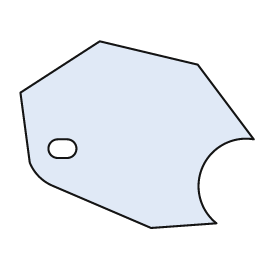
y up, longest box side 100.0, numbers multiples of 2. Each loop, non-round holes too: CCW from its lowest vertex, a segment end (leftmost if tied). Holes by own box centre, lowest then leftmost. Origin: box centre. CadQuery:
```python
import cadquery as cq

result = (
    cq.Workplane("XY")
    .moveTo(6.0, -40.0)
    .lineTo(34.0, -38.0)
    .threePointArc((28.0, -14.0), (50.0, -2.0))
    .lineTo(26.0, 30.0)
    .lineTo(-16.0, 40.0)
    .lineTo(-50.0, 18.0)
    .lineTo(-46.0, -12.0)
    .threePointArc((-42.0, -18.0), (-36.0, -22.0))
    .close()
    .moveTo(-34.0, -10.0)
    .lineTo(-30.0, -10.0)
    .threePointArc((-26.0, -6.0), (-30.0, -2.0))
    .lineTo(-34.0, -2.0)
    .threePointArc((-38.0, -6.0), (-34.0, -10.0))
    .close()
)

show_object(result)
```